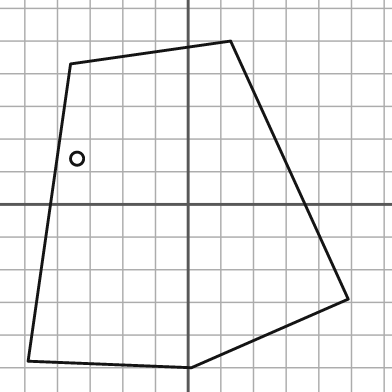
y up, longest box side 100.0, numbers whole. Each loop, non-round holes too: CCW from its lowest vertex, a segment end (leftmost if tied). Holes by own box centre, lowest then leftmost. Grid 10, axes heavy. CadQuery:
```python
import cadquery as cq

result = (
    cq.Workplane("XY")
    .moveTo(1.0, -50.0)
    .lineTo(49.0, -29.0)
    .lineTo(13.0, 50.0)
    .lineTo(-36.0, 43.0)
    .lineTo(-49.0, -48.0)
    .close()
    .moveTo(-34.0, 14.0)
    .circle(2.0)
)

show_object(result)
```